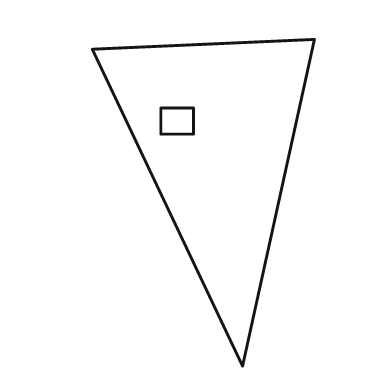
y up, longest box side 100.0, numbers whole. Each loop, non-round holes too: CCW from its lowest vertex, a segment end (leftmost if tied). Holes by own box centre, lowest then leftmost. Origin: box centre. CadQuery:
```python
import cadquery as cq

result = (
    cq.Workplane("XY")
    .moveTo(12.0, -50.0)
    .lineTo(34.0, 50.0)
    .lineTo(-34.0, 47.0)
    .close()
    .moveTo(-13.0, 21.0)
    .lineTo(-3.0, 21.0)
    .lineTo(-3.0, 29.0)
    .lineTo(-13.0, 29.0)
    .close()
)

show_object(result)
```